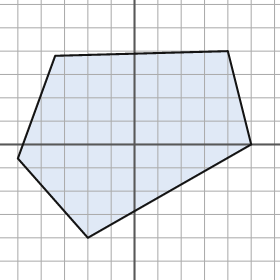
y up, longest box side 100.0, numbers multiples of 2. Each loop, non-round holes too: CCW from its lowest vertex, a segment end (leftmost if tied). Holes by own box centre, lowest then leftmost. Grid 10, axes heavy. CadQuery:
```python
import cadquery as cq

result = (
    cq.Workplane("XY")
    .moveTo(-20.0, -40.0)
    .lineTo(50.0, 0.0)
    .lineTo(40.0, 40.0)
    .lineTo(-34.0, 38.0)
    .lineTo(-50.0, -6.0)
    .close()
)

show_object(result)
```